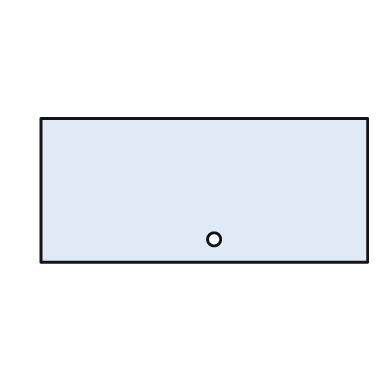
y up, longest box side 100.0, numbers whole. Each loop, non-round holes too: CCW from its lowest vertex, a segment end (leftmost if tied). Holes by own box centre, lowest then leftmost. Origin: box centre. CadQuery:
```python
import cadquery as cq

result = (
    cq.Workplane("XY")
    .moveTo(-50.0, -22.0)
    .lineTo(50.0, -22.0)
    .lineTo(50.0, 22.0)
    .lineTo(-50.0, 22.0)
    .close()
    .moveTo(3.0, -15.0)
    .circle(2.0)
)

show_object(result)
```